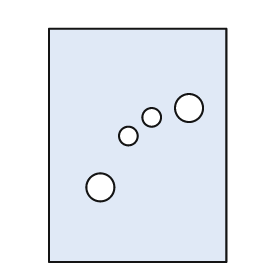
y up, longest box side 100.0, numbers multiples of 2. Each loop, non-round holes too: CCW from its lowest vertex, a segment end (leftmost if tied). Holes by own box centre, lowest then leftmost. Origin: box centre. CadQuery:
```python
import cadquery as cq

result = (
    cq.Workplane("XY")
    .moveTo(-38.0, -50.0)
    .lineTo(38.0, -50.0)
    .lineTo(38.0, 50.0)
    .lineTo(-38.0, 50.0)
    .close()
    .moveTo(-16.0, -18.0)
    .circle(6.0)
    .moveTo(-4.0, 4.0)
    .circle(4.0)
    .moveTo(6.0, 12.0)
    .circle(4.0)
    .moveTo(22.0, 16.0)
    .circle(6.0)
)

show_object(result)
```